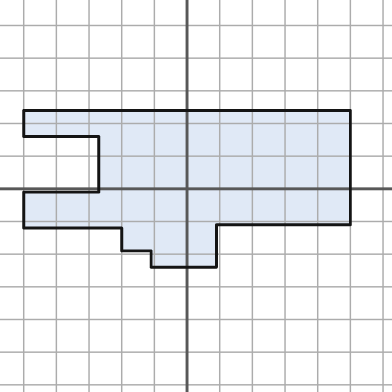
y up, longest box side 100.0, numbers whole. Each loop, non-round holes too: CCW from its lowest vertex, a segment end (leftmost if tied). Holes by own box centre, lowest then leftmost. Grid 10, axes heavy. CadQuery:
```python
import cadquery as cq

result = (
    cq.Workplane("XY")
    .moveTo(-11.0, -24.0)
    .lineTo(9.0, -24.0)
    .lineTo(9.0, -11.0)
    .lineTo(50.0, -11.0)
    .lineTo(50.0, 24.0)
    .lineTo(-50.0, 24.0)
    .lineTo(-50.0, 16.0)
    .lineTo(-27.0, 16.0)
    .lineTo(-27.0, -1.0)
    .lineTo(-50.0, -1.0)
    .lineTo(-50.0, -12.0)
    .lineTo(-20.0, -12.0)
    .lineTo(-20.0, -19.0)
    .lineTo(-11.0, -19.0)
    .close()
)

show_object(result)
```